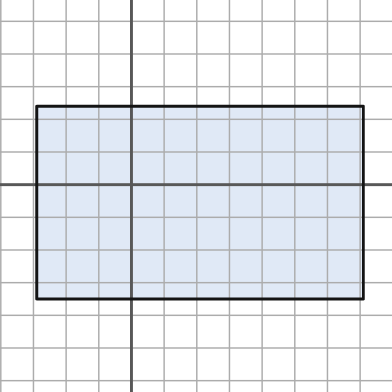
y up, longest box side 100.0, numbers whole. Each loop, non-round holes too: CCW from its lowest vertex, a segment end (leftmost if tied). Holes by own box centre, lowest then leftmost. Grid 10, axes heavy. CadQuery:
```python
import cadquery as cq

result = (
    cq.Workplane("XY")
    .moveTo(-29.0, -35.0)
    .lineTo(71.0, -35.0)
    .lineTo(71.0, 24.0)
    .lineTo(-29.0, 24.0)
    .close()
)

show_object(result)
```